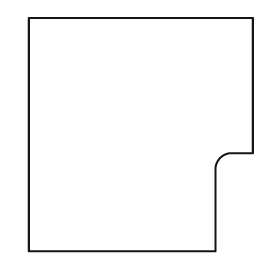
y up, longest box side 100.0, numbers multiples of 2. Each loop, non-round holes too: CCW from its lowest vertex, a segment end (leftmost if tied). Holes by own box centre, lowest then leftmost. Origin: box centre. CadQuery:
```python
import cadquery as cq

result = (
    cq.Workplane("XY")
    .moveTo(-48.0, -50.0)
    .lineTo(32.0, -50.0)
    .lineTo(32.0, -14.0)
    .threePointArc((34.0, -10.0), (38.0, -8.0))
    .lineTo(48.0, -8.0)
    .lineTo(48.0, 50.0)
    .lineTo(-48.0, 50.0)
    .close()
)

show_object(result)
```